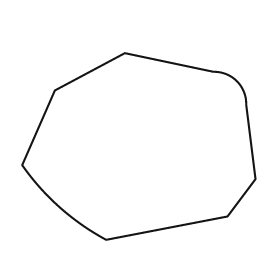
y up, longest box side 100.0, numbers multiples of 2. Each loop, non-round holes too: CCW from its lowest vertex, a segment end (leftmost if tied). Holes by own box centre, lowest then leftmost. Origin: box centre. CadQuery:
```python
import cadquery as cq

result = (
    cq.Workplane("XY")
    .moveTo(-14.0, -40.0)
    .lineTo(38.0, -30.0)
    .lineTo(50.0, -14.0)
    .lineTo(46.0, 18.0)
    .threePointArc((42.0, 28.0), (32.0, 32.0))
    .lineTo(-6.0, 40.0)
    .lineTo(-36.0, 24.0)
    .lineTo(-50.0, -8.0)
    .threePointArc((-34.0, -26.0), (-14.0, -40.0))
    .close()
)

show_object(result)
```